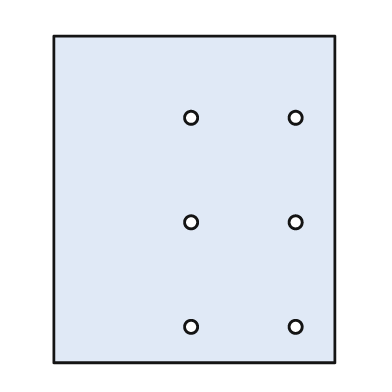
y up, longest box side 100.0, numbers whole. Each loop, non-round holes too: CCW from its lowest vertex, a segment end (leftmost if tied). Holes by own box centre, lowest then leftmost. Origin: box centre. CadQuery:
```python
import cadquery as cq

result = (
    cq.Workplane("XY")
    .moveTo(-43.0, -50.0)
    .lineTo(43.0, -50.0)
    .lineTo(43.0, 50.0)
    .lineTo(-43.0, 50.0)
    .close()
    .moveTo(-1.0, -39.0)
    .circle(2.0)
    .moveTo(31.0, -39.0)
    .circle(2.0)
    .moveTo(-1.0, -7.0)
    .circle(2.0)
    .moveTo(31.0, -7.0)
    .circle(2.0)
    .moveTo(-1.0, 25.0)
    .circle(2.0)
    .moveTo(31.0, 25.0)
    .circle(2.0)
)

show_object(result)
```